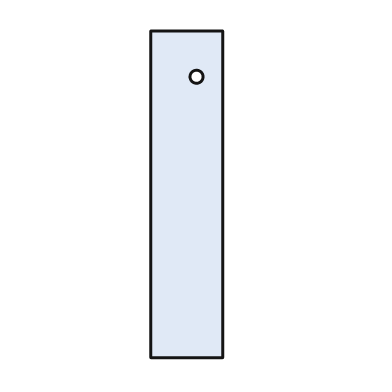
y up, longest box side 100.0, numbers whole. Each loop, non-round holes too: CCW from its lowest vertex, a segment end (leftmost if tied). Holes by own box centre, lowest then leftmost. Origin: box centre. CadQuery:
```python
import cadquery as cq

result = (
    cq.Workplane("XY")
    .moveTo(-11.0, -50.0)
    .lineTo(11.0, -50.0)
    .lineTo(11.0, 50.0)
    .lineTo(-11.0, 50.0)
    .close()
    .moveTo(3.0, 36.0)
    .circle(2.0)
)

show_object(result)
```